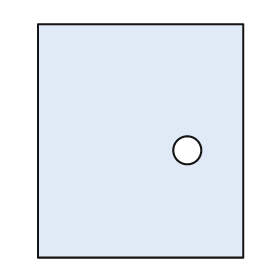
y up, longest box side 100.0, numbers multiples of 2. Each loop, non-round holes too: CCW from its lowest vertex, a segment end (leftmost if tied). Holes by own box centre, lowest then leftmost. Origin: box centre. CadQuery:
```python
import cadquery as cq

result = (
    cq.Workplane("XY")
    .moveTo(-44.0, -50.0)
    .lineTo(44.0, -50.0)
    .lineTo(44.0, 50.0)
    .lineTo(-44.0, 50.0)
    .close()
    .moveTo(20.0, -4.0)
    .circle(6.0)
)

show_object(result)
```